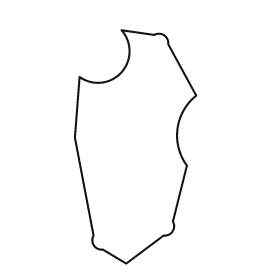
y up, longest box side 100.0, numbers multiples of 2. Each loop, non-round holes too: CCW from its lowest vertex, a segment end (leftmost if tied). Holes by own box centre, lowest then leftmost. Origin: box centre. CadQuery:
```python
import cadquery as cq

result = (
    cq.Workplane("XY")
    .moveTo(-4.0, -50.0)
    .lineTo(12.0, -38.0)
    .threePointArc((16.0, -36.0), (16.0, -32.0))
    .lineTo(22.0, -8.0)
    .threePointArc((18.0, 8.0), (26.0, 22.0))
    .lineTo(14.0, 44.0)
    .threePointArc((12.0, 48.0), (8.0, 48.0))
    .lineTo(-6.0, 50.0)
    .threePointArc((-6.0, 32.0), (-24.0, 30.0))
    .lineTo(-26.0, 4.0)
    .lineTo(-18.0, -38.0)
    .threePointArc((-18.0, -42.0), (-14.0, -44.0))
    .close()
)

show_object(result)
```